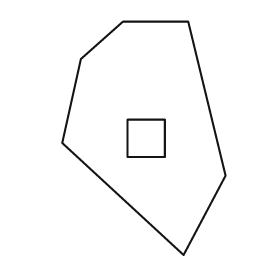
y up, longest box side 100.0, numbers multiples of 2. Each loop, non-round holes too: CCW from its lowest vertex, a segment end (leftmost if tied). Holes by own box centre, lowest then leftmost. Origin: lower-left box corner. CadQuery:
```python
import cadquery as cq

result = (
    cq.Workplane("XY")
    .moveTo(52.0, 0.0)
    .lineTo(70.0, 34.0)
    .lineTo(54.0, 100.0)
    .lineTo(26.0, 100.0)
    .lineTo(8.0, 84.0)
    .lineTo(0.0, 48.0)
    .close()
    .moveTo(28.0, 42.0)
    .lineTo(44.0, 42.0)
    .lineTo(44.0, 58.0)
    .lineTo(28.0, 58.0)
    .close()
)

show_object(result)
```